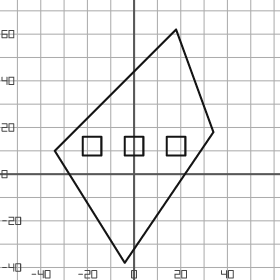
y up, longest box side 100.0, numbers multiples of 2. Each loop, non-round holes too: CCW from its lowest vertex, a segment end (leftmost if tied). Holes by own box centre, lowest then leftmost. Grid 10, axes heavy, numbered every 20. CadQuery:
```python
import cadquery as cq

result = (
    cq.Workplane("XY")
    .moveTo(-4.0, -38.0)
    .lineTo(34.0, 18.0)
    .lineTo(18.0, 62.0)
    .lineTo(-34.0, 10.0)
    .close()
    .moveTo(-22.0, 8.0)
    .lineTo(-14.0, 8.0)
    .lineTo(-14.0, 16.0)
    .lineTo(-22.0, 16.0)
    .close()
    .moveTo(-4.0, 8.0)
    .lineTo(4.0, 8.0)
    .lineTo(4.0, 16.0)
    .lineTo(-4.0, 16.0)
    .close()
    .moveTo(14.0, 8.0)
    .lineTo(22.0, 8.0)
    .lineTo(22.0, 16.0)
    .lineTo(14.0, 16.0)
    .close()
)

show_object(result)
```